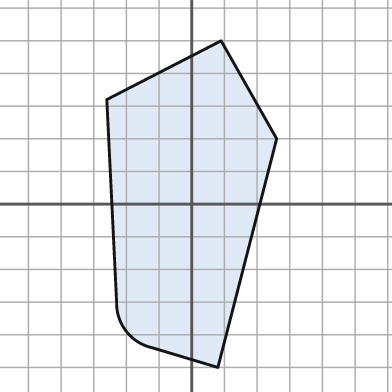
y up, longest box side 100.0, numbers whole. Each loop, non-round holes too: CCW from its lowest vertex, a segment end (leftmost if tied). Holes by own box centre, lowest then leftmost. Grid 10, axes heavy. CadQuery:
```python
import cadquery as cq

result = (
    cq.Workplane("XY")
    .moveTo(8.0, -50.0)
    .lineTo(26.0, 20.0)
    .lineTo(9.0, 50.0)
    .lineTo(-26.0, 32.0)
    .lineTo(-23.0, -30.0)
    .threePointArc((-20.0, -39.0), (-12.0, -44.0))
    .close()
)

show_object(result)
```